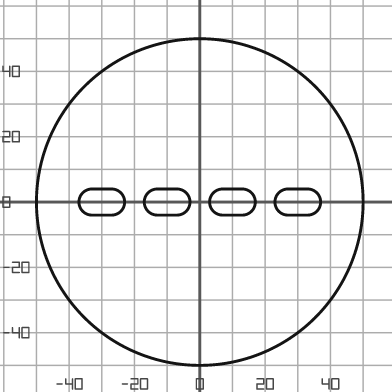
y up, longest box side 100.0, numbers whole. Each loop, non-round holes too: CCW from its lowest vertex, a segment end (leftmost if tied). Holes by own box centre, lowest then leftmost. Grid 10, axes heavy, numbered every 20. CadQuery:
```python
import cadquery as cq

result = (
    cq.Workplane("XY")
    .moveTo(0.0, 0.0)
    .circle(50.0)
    .moveTo(-33.0, -4.0)
    .lineTo(-27.0, -4.0)
    .threePointArc((-23.0, 0.0), (-27.0, 4.0))
    .lineTo(-33.0, 4.0)
    .threePointArc((-37.0, 0.0), (-33.0, -4.0))
    .close()
    .moveTo(-13.0, -4.0)
    .lineTo(-7.0, -4.0)
    .threePointArc((-3.0, 0.0), (-7.0, 4.0))
    .lineTo(-13.0, 4.0)
    .threePointArc((-17.0, 0.0), (-13.0, -4.0))
    .close()
    .moveTo(7.0, -4.0)
    .lineTo(13.0, -4.0)
    .threePointArc((17.0, 0.0), (13.0, 4.0))
    .lineTo(7.0, 4.0)
    .threePointArc((3.0, 0.0), (7.0, -4.0))
    .close()
    .moveTo(27.0, -4.0)
    .lineTo(33.0, -4.0)
    .threePointArc((37.0, 0.0), (33.0, 4.0))
    .lineTo(27.0, 4.0)
    .threePointArc((23.0, 0.0), (27.0, -4.0))
    .close()
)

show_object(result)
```